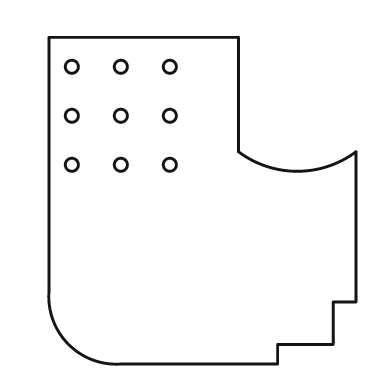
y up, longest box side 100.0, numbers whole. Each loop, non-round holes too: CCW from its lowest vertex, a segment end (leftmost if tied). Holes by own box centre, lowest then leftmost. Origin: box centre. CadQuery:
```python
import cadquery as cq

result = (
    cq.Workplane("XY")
    .moveTo(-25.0, -50.0)
    .lineTo(23.0, -50.0)
    .lineTo(23.0, -44.0)
    .lineTo(40.0, -44.0)
    .lineTo(40.0, -31.0)
    .lineTo(47.0, -31.0)
    .lineTo(47.0, 15.0)
    .threePointArc((29.0, 9.0), (11.0, 15.0))
    .lineTo(11.0, 50.0)
    .lineTo(-47.0, 50.0)
    .lineTo(-47.0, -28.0)
    .threePointArc((-41.0, -44.0), (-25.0, -50.0))
    .close()
    .moveTo(-40.0, 11.0)
    .circle(2.0)
    .moveTo(-25.0, 11.0)
    .circle(2.0)
    .moveTo(-10.0, 11.0)
    .circle(2.0)
    .moveTo(-40.0, 26.0)
    .circle(2.0)
    .moveTo(-25.0, 26.0)
    .circle(2.0)
    .moveTo(-10.0, 26.0)
    .circle(2.0)
    .moveTo(-40.0, 41.0)
    .circle(2.0)
    .moveTo(-25.0, 41.0)
    .circle(2.0)
    .moveTo(-10.0, 41.0)
    .circle(2.0)
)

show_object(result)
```